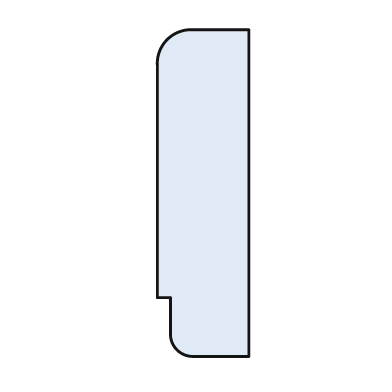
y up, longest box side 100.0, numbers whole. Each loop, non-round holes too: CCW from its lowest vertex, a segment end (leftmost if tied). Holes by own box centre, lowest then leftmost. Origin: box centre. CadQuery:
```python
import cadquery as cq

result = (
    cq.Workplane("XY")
    .moveTo(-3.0, -50.0)
    .lineTo(14.0, -50.0)
    .lineTo(14.0, 50.0)
    .lineTo(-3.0, 50.0)
    .threePointArc((-11.0, 47.0), (-14.0, 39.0))
    .lineTo(-14.0, -32.0)
    .lineTo(-10.0, -32.0)
    .lineTo(-10.0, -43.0)
    .threePointArc((-8.0, -48.0), (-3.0, -50.0))
    .close()
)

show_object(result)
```